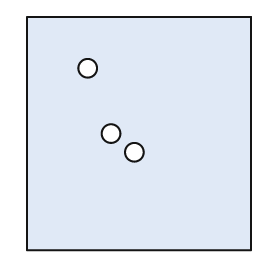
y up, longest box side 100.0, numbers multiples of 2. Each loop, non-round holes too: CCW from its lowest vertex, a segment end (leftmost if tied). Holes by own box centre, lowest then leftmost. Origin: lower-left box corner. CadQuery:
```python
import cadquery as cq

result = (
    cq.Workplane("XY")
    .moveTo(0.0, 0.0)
    .lineTo(96.0, 0.0)
    .lineTo(96.0, 100.0)
    .lineTo(0.0, 100.0)
    .close()
    .moveTo(46.0, 42.0)
    .circle(4.0)
    .moveTo(36.0, 50.0)
    .circle(4.0)
    .moveTo(26.0, 78.0)
    .circle(4.0)
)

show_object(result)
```